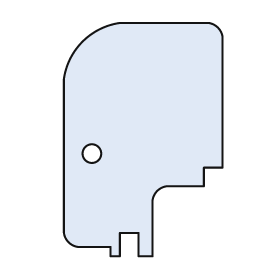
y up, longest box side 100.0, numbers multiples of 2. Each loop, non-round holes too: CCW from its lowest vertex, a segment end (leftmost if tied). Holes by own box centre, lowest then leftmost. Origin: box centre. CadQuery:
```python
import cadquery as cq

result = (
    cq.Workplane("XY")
    .moveTo(-14.0, -50.0)
    .lineTo(-10.0, -50.0)
    .lineTo(-10.0, -40.0)
    .lineTo(-2.0, -40.0)
    .lineTo(-2.0, -50.0)
    .lineTo(4.0, -50.0)
    .lineTo(4.0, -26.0)
    .threePointArc((6.0, -22.0), (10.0, -20.0))
    .lineTo(26.0, -20.0)
    .lineTo(26.0, -12.0)
    .lineTo(34.0, -12.0)
    .lineTo(34.0, 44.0)
    .threePointArc((32.0, 48.0), (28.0, 50.0))
    .lineTo(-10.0, 50.0)
    .threePointArc((-26.0, 42.0), (-34.0, 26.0))
    .lineTo(-34.0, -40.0)
    .threePointArc((-32.0, -44.0), (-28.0, -46.0))
    .lineTo(-14.0, -46.0)
    .close()
    .moveTo(-22.0, -6.0)
    .circle(4.0)
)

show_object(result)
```